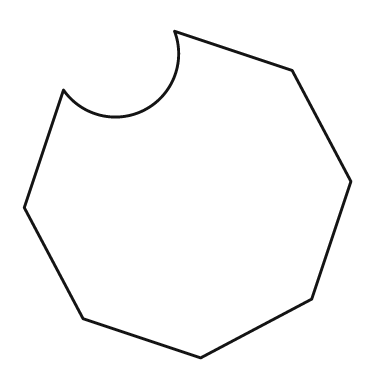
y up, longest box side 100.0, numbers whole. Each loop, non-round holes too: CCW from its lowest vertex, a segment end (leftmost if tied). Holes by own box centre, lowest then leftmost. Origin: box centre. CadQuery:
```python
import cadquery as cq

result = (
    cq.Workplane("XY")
    .moveTo(4.0, -50.0)
    .lineTo(38.0, -32.0)
    .lineTo(50.0, 4.0)
    .lineTo(32.0, 38.0)
    .lineTo(-4.0, 50.0)
    .threePointArc((-13.0, 26.0), (-38.0, 32.0))
    .lineTo(-50.0, -4.0)
    .lineTo(-32.0, -38.0)
    .close()
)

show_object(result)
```